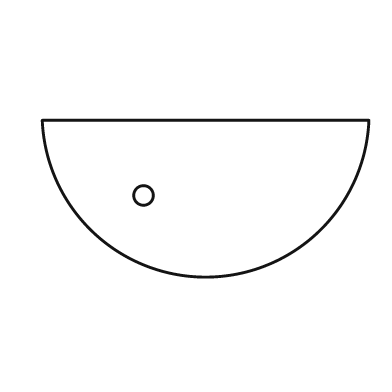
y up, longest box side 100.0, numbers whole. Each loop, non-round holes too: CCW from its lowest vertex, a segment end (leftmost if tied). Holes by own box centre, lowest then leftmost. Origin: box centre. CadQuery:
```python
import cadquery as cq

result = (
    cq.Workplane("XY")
    .moveTo(-50.0, 24.0)
    .threePointArc((0.0, -24.0), (50.0, 24.0))
    .close()
    .moveTo(-19.0, 1.0)
    .circle(3.0)
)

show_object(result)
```